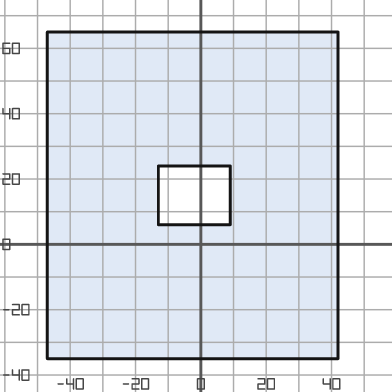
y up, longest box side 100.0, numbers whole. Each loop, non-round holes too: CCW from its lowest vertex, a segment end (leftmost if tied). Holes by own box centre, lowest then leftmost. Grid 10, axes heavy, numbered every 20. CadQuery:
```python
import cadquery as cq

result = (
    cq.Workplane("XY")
    .moveTo(-47.0, -35.0)
    .lineTo(42.0, -35.0)
    .lineTo(42.0, 65.0)
    .lineTo(-47.0, 65.0)
    .close()
    .moveTo(-13.0, 6.0)
    .lineTo(9.0, 6.0)
    .lineTo(9.0, 24.0)
    .lineTo(-13.0, 24.0)
    .close()
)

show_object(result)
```